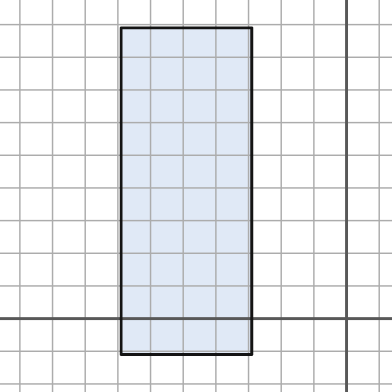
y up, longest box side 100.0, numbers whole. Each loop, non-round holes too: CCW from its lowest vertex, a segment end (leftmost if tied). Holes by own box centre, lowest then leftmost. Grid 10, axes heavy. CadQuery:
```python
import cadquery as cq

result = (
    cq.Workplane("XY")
    .moveTo(-69.0, -11.0)
    .lineTo(-29.0, -11.0)
    .lineTo(-29.0, 89.0)
    .lineTo(-69.0, 89.0)
    .close()
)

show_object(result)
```